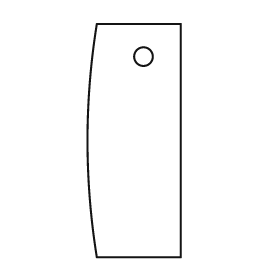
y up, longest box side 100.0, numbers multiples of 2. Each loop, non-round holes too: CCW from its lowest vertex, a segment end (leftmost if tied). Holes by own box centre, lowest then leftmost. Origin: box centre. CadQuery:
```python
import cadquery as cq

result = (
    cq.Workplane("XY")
    .moveTo(-16.0, -50.0)
    .lineTo(20.0, -50.0)
    .lineTo(20.0, 50.0)
    .lineTo(-16.0, 50.0)
    .threePointArc((-20.0, 0.0), (-16.0, -50.0))
    .close()
    .moveTo(4.0, 36.0)
    .circle(4.0)
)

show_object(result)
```